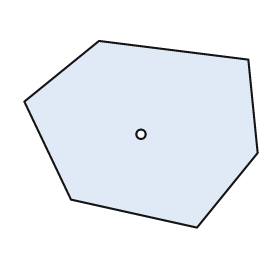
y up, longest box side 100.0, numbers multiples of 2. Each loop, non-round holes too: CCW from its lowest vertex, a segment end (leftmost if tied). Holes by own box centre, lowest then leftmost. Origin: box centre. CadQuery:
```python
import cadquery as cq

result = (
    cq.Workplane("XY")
    .moveTo(24.0, -40.0)
    .lineTo(50.0, -8.0)
    .lineTo(46.0, 32.0)
    .lineTo(-18.0, 40.0)
    .lineTo(-50.0, 14.0)
    .lineTo(-30.0, -28.0)
    .close()
    .moveTo(0.0, 0.0)
    .circle(2.0)
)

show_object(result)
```